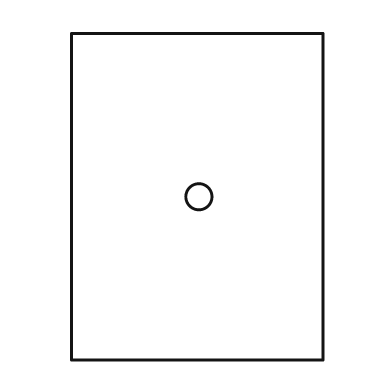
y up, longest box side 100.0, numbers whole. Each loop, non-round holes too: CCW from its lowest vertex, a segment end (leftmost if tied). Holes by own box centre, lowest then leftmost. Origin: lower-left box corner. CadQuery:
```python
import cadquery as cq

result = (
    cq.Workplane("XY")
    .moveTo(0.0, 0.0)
    .lineTo(77.0, 0.0)
    .lineTo(77.0, 100.0)
    .lineTo(0.0, 100.0)
    .close()
    .moveTo(39.0, 50.0)
    .circle(4.0)
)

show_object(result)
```